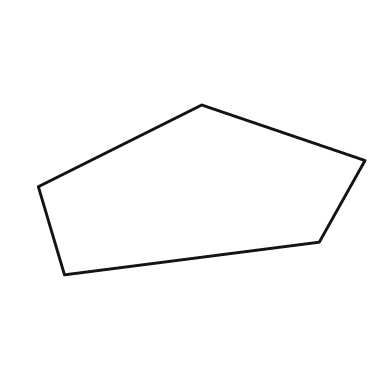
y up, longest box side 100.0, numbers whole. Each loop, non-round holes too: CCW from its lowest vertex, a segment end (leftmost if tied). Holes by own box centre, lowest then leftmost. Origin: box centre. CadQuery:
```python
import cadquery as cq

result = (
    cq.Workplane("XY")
    .moveTo(-42.0, -26.0)
    .lineTo(36.0, -16.0)
    .lineTo(50.0, 9.0)
    .lineTo(0.0, 26.0)
    .lineTo(-50.0, 1.0)
    .close()
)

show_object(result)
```